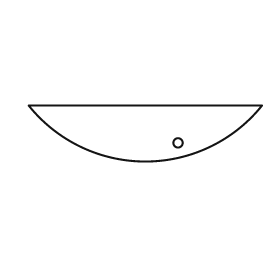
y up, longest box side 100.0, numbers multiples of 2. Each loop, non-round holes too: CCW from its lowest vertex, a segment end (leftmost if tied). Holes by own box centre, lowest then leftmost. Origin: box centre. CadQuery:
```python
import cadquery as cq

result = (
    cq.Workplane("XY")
    .moveTo(-50.0, 12.0)
    .threePointArc((0.0, -12.0), (50.0, 12.0))
    .close()
    .moveTo(14.0, -4.0)
    .circle(2.0)
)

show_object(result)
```